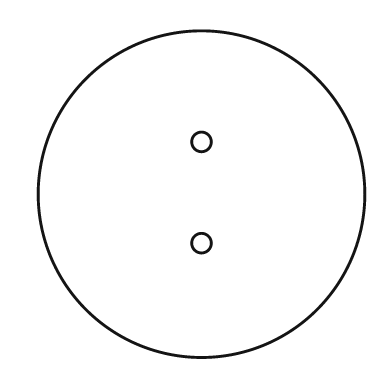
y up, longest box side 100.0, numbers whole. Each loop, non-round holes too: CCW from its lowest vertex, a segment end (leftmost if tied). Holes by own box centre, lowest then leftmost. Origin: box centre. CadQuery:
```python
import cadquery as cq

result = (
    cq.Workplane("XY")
    .moveTo(0.0, 0.0)
    .circle(50.0)
    .moveTo(0.0, -15.0)
    .circle(3.0)
    .moveTo(0.0, 16.0)
    .circle(3.0)
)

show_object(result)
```